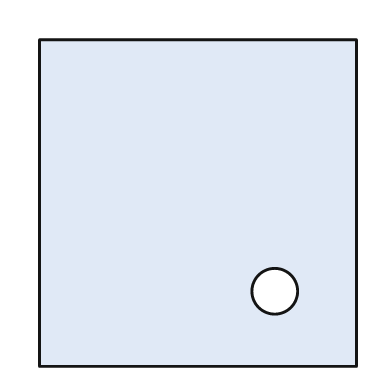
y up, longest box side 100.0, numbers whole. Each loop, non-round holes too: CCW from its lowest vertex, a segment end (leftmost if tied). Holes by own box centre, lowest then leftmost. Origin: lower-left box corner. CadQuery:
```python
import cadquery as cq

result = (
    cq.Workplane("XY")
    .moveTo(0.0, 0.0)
    .lineTo(97.0, 0.0)
    .lineTo(97.0, 100.0)
    .lineTo(0.0, 100.0)
    .close()
    .moveTo(72.0, 23.0)
    .circle(7.0)
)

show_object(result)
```